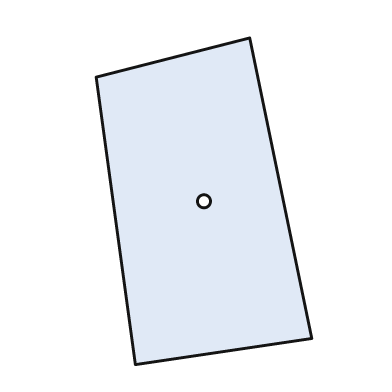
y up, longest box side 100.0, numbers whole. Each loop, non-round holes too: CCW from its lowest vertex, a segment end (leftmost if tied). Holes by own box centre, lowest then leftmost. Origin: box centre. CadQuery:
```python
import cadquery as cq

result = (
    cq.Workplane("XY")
    .moveTo(-21.0, -50.0)
    .lineTo(33.0, -42.0)
    .lineTo(14.0, 50.0)
    .lineTo(-33.0, 38.0)
    .close()
    .moveTo(0.0, 0.0)
    .circle(2.0)
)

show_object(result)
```